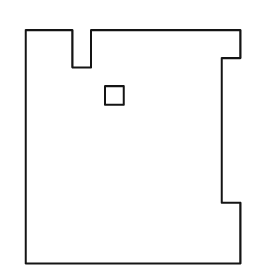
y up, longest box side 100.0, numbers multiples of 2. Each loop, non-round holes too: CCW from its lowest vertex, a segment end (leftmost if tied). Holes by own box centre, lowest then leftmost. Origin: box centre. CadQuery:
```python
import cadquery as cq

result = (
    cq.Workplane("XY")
    .moveTo(-46.0, -50.0)
    .lineTo(46.0, -50.0)
    .lineTo(46.0, -24.0)
    .lineTo(38.0, -24.0)
    .lineTo(38.0, 38.0)
    .lineTo(46.0, 38.0)
    .lineTo(46.0, 50.0)
    .lineTo(-18.0, 50.0)
    .lineTo(-18.0, 34.0)
    .lineTo(-26.0, 34.0)
    .lineTo(-26.0, 50.0)
    .lineTo(-46.0, 50.0)
    .close()
    .moveTo(-12.0, 18.0)
    .lineTo(-4.0, 18.0)
    .lineTo(-4.0, 26.0)
    .lineTo(-12.0, 26.0)
    .close()
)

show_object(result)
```